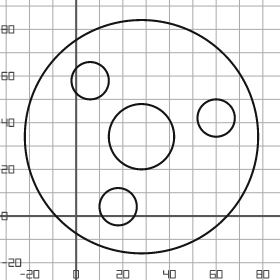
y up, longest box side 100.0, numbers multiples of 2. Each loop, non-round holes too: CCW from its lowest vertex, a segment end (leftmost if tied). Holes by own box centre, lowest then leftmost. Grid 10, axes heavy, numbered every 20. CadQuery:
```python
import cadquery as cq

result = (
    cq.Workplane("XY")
    .moveTo(28.0, 34.0)
    .circle(50.0)
    .moveTo(18.0, 4.0)
    .circle(8.0)
    .moveTo(28.0, 34.0)
    .circle(14.0)
    .moveTo(60.0, 42.0)
    .circle(8.0)
    .moveTo(6.0, 58.0)
    .circle(8.0)
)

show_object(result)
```